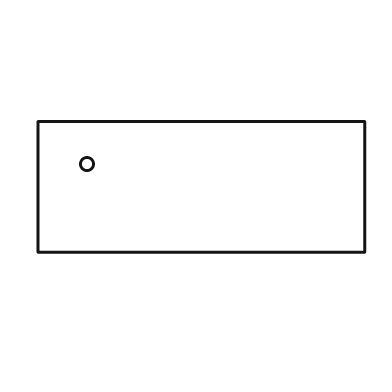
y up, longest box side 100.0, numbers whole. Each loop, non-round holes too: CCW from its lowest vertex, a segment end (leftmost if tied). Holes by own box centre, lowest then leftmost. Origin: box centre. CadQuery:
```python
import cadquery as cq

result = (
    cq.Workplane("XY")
    .moveTo(-50.0, -20.0)
    .lineTo(50.0, -20.0)
    .lineTo(50.0, 20.0)
    .lineTo(-50.0, 20.0)
    .close()
    .moveTo(-35.0, 7.0)
    .circle(2.0)
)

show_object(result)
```